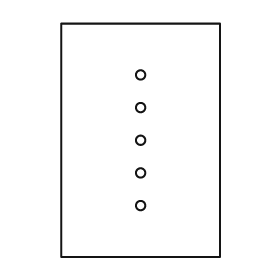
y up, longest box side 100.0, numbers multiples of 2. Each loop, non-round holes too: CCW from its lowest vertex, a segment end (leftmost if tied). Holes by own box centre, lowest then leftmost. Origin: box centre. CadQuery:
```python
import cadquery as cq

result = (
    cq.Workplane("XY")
    .moveTo(-34.0, -50.0)
    .lineTo(34.0, -50.0)
    .lineTo(34.0, 50.0)
    .lineTo(-34.0, 50.0)
    .close()
    .moveTo(0.0, -28.0)
    .circle(2.0)
    .moveTo(0.0, -14.0)
    .circle(2.0)
    .moveTo(0.0, 0.0)
    .circle(2.0)
    .moveTo(0.0, 14.0)
    .circle(2.0)
    .moveTo(0.0, 28.0)
    .circle(2.0)
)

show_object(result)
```